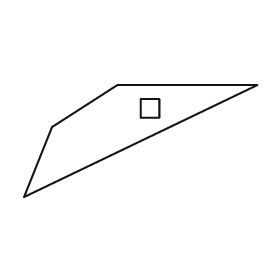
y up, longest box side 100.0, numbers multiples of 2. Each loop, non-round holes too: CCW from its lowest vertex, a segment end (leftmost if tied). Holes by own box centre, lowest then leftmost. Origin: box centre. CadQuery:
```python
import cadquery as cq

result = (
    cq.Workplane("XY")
    .moveTo(-50.0, -24.0)
    .lineTo(50.0, 24.0)
    .lineTo(-10.0, 24.0)
    .lineTo(-38.0, 6.0)
    .close()
    .moveTo(0.0, 10.0)
    .lineTo(8.0, 10.0)
    .lineTo(8.0, 18.0)
    .lineTo(0.0, 18.0)
    .close()
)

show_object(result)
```